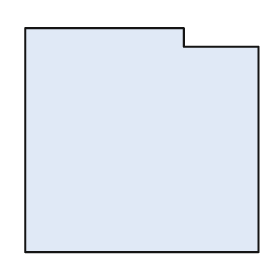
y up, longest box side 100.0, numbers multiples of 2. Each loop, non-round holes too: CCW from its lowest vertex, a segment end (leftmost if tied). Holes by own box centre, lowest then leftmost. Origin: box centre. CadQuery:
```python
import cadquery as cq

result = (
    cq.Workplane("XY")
    .moveTo(-50.0, -48.0)
    .lineTo(50.0, -48.0)
    .lineTo(50.0, 40.0)
    .lineTo(18.0, 40.0)
    .lineTo(18.0, 48.0)
    .lineTo(-50.0, 48.0)
    .close()
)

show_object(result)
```